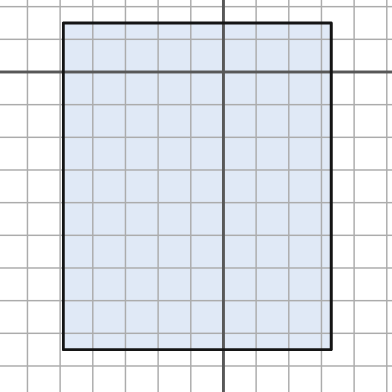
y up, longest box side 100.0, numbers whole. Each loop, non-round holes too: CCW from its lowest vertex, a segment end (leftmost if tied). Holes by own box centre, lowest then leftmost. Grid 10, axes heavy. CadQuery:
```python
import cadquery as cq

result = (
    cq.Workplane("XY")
    .moveTo(-49.0, -85.0)
    .lineTo(33.0, -85.0)
    .lineTo(33.0, 15.0)
    .lineTo(-49.0, 15.0)
    .close()
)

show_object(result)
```